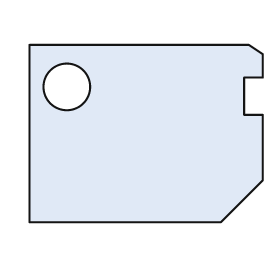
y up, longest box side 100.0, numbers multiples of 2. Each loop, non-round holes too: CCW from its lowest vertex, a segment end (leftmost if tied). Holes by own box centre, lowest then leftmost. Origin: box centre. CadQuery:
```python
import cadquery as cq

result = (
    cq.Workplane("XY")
    .moveTo(-50.0, -38.0)
    .lineTo(32.0, -38.0)
    .lineTo(50.0, -20.0)
    .lineTo(50.0, 8.0)
    .lineTo(42.0, 8.0)
    .lineTo(42.0, 24.0)
    .lineTo(50.0, 24.0)
    .lineTo(50.0, 34.0)
    .lineTo(44.0, 38.0)
    .lineTo(-50.0, 38.0)
    .close()
    .moveTo(-34.0, 20.0)
    .circle(10.0)
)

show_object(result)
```